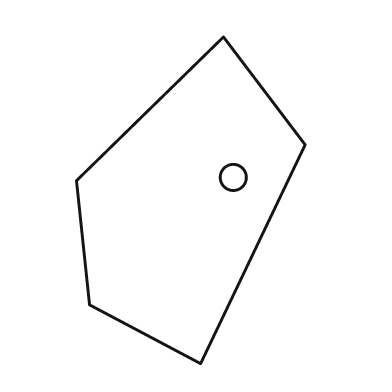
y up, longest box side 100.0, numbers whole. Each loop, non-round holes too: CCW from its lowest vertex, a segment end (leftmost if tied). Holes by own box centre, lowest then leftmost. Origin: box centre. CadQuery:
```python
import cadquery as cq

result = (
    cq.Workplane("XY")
    .moveTo(3.0, -50.0)
    .lineTo(35.0, 17.0)
    .lineTo(10.0, 50.0)
    .lineTo(-35.0, 6.0)
    .lineTo(-31.0, -32.0)
    .close()
    .moveTo(13.0, 7.0)
    .circle(4.0)
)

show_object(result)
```